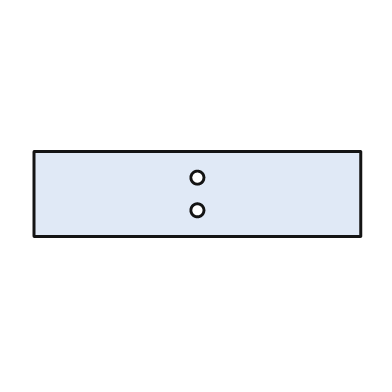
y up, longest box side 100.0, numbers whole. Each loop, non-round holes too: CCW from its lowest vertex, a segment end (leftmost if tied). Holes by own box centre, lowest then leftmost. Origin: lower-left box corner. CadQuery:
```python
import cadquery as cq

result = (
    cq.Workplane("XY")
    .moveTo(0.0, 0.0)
    .lineTo(100.0, 0.0)
    .lineTo(100.0, 26.0)
    .lineTo(0.0, 26.0)
    .close()
    .moveTo(50.0, 8.0)
    .circle(2.0)
    .moveTo(50.0, 18.0)
    .circle(2.0)
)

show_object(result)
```